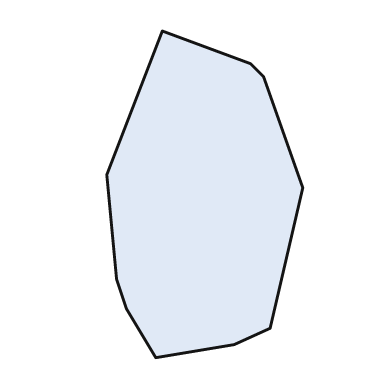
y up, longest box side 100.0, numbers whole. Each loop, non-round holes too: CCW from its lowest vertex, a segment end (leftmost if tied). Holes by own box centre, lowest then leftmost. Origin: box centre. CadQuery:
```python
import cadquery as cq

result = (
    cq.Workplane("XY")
    .moveTo(-15.0, -50.0)
    .lineTo(9.0, -46.0)
    .lineTo(20.0, -41.0)
    .lineTo(30.0, 2.0)
    .lineTo(18.0, 36.0)
    .lineTo(14.0, 40.0)
    .lineTo(-13.0, 50.0)
    .lineTo(-30.0, 6.0)
    .lineTo(-27.0, -26.0)
    .lineTo(-24.0, -35.0)
    .close()
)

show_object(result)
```